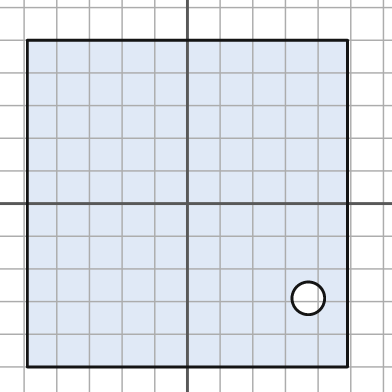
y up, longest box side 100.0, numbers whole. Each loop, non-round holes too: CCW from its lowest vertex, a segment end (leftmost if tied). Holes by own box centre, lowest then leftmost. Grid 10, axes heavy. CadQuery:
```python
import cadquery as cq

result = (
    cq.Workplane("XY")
    .moveTo(-49.0, -50.0)
    .lineTo(49.0, -50.0)
    .lineTo(49.0, 50.0)
    .lineTo(-49.0, 50.0)
    .close()
    .moveTo(37.0, -29.0)
    .circle(5.0)
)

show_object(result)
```